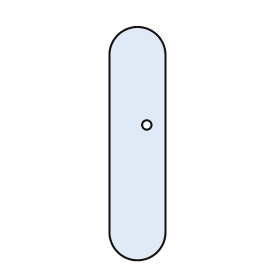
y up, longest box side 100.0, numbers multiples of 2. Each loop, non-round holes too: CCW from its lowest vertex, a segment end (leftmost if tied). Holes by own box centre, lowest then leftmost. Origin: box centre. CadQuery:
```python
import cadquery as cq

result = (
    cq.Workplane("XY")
    .moveTo(-12.0, -38.0)
    .threePointArc((0.0, -50.0), (12.0, -38.0))
    .lineTo(12.0, 38.0)
    .threePointArc((0.0, 50.0), (-12.0, 38.0))
    .close()
    .moveTo(4.0, 8.0)
    .circle(2.0)
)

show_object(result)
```